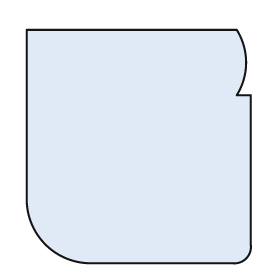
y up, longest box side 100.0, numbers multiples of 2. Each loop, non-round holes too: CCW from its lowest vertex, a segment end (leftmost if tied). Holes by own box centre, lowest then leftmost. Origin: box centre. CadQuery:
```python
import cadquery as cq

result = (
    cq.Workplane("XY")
    .moveTo(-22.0, -50.0)
    .lineTo(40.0, -50.0)
    .threePointArc((46.0, -48.0), (48.0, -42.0))
    .lineTo(48.0, 22.0)
    .lineTo(42.0, 22.0)
    .threePointArc((46.0, 36.0), (42.0, 50.0))
    .lineTo(-48.0, 50.0)
    .lineTo(-48.0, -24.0)
    .threePointArc((-40.0, -42.0), (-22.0, -50.0))
    .close()
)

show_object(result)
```